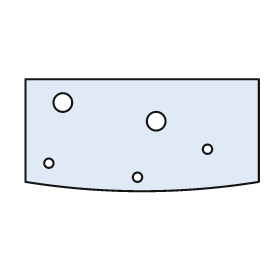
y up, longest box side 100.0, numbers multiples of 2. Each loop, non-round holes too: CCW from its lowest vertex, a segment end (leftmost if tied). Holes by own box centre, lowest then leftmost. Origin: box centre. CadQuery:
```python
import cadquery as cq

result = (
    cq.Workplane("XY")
    .moveTo(-50.0, -20.0)
    .threePointArc((0.0, -24.0), (50.0, -20.0))
    .lineTo(50.0, 24.0)
    .lineTo(-50.0, 24.0)
    .close()
    .moveTo(-2.0, -18.0)
    .circle(2.0)
    .moveTo(-40.0, -12.0)
    .circle(2.0)
    .moveTo(28.0, -6.0)
    .circle(2.0)
    .moveTo(6.0, 6.0)
    .circle(4.0)
    .moveTo(-34.0, 14.0)
    .circle(4.0)
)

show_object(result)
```